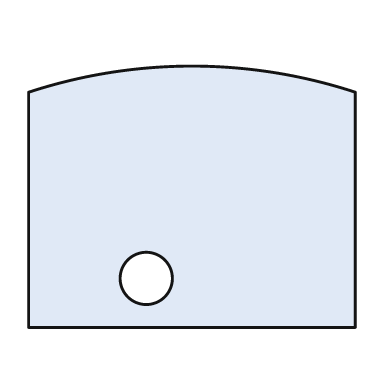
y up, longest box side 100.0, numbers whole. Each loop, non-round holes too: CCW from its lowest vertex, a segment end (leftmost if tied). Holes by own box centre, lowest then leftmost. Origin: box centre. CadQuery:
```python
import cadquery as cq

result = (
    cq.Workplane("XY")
    .moveTo(-50.0, -40.0)
    .lineTo(50.0, -40.0)
    .lineTo(50.0, 32.0)
    .threePointArc((0.0, 40.0), (-50.0, 32.0))
    .close()
    .moveTo(-14.0, -25.0)
    .circle(8.0)
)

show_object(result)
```